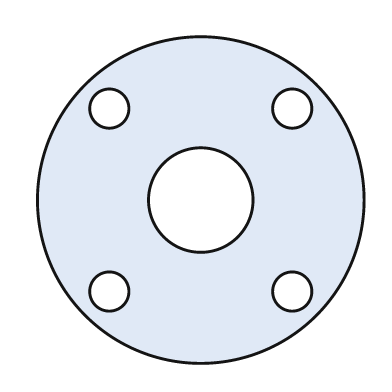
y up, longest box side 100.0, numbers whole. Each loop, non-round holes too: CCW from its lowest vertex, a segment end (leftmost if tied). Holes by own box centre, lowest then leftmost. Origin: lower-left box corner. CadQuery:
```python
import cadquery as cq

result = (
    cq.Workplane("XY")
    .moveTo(50.0, 50.0)
    .circle(50.0)
    .moveTo(22.0, 22.0)
    .circle(6.0)
    .moveTo(78.0, 22.0)
    .circle(6.0)
    .moveTo(50.0, 50.0)
    .circle(16.0)
    .moveTo(22.0, 78.0)
    .circle(6.0)
    .moveTo(78.0, 78.0)
    .circle(6.0)
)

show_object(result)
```